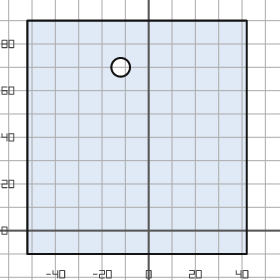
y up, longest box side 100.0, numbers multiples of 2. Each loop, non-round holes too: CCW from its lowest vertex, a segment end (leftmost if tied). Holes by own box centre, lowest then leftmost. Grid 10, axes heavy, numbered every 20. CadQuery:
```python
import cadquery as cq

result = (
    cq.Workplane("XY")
    .moveTo(-52.0, -10.0)
    .lineTo(42.0, -10.0)
    .lineTo(42.0, 90.0)
    .lineTo(-52.0, 90.0)
    .close()
    .moveTo(-12.0, 70.0)
    .circle(4.0)
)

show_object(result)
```